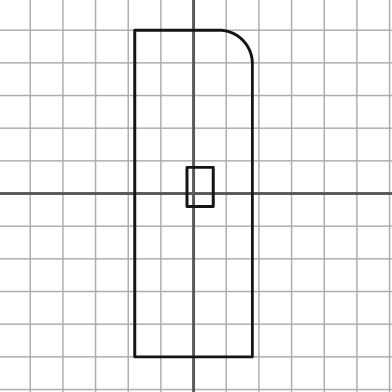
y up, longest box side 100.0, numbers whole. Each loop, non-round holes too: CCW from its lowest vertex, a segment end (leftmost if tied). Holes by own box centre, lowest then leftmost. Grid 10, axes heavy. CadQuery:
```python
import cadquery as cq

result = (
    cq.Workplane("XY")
    .moveTo(-18.0, -50.0)
    .lineTo(18.0, -50.0)
    .lineTo(18.0, 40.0)
    .threePointArc((15.0, 47.0), (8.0, 50.0))
    .lineTo(-18.0, 50.0)
    .close()
    .moveTo(-2.0, -4.0)
    .lineTo(6.0, -4.0)
    .lineTo(6.0, 8.0)
    .lineTo(-2.0, 8.0)
    .close()
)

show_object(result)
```